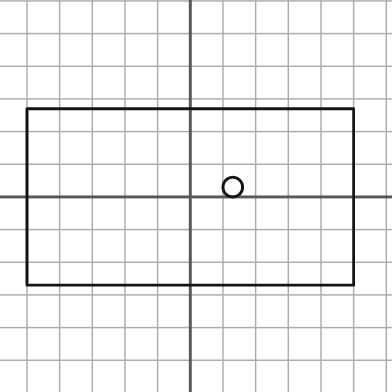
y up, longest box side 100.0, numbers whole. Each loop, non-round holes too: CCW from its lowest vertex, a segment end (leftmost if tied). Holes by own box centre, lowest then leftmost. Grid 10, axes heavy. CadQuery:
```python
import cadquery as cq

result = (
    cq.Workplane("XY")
    .moveTo(-50.0, -27.0)
    .lineTo(50.0, -27.0)
    .lineTo(50.0, 27.0)
    .lineTo(-50.0, 27.0)
    .close()
    .moveTo(13.0, 3.0)
    .circle(3.0)
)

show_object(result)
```